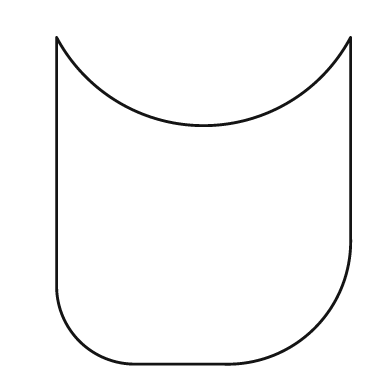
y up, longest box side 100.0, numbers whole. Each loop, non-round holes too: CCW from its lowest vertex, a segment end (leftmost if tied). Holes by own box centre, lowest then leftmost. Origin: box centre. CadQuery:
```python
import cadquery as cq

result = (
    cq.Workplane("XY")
    .moveTo(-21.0, -50.0)
    .lineTo(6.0, -50.0)
    .threePointArc((34.0, -39.0), (45.0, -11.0))
    .lineTo(45.0, 50.0)
    .threePointArc((0.0, 23.0), (-45.0, 50.0))
    .lineTo(-45.0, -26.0)
    .threePointArc((-38.0, -43.0), (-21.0, -50.0))
    .close()
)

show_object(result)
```